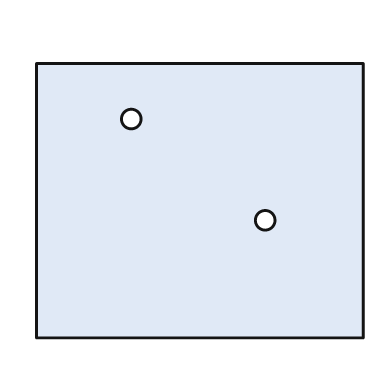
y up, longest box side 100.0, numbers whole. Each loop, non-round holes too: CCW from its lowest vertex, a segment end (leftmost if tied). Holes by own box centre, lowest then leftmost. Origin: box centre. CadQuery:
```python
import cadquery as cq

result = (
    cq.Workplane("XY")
    .moveTo(-50.0, -42.0)
    .lineTo(50.0, -42.0)
    .lineTo(50.0, 42.0)
    .lineTo(-50.0, 42.0)
    .close()
    .moveTo(20.0, -6.0)
    .circle(3.0)
    .moveTo(-21.0, 25.0)
    .circle(3.0)
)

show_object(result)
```